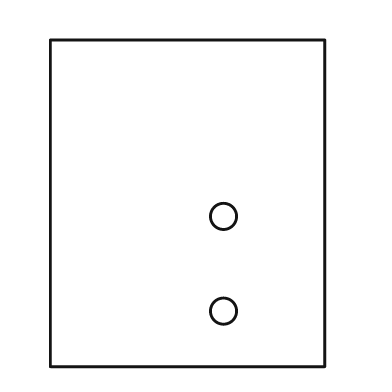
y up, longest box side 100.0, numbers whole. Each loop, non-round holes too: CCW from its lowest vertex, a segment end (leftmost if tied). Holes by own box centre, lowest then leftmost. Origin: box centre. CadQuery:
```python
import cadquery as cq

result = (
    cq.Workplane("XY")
    .moveTo(-42.0, -50.0)
    .lineTo(42.0, -50.0)
    .lineTo(42.0, 50.0)
    .lineTo(-42.0, 50.0)
    .close()
    .moveTo(11.0, -33.0)
    .circle(4.0)
    .moveTo(11.0, -4.0)
    .circle(4.0)
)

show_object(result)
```